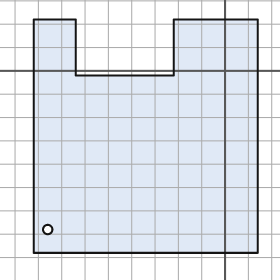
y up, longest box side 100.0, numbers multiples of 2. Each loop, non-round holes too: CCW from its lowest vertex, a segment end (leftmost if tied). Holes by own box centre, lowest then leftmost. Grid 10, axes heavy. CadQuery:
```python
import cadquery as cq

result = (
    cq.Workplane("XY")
    .moveTo(-82.0, -78.0)
    .lineTo(14.0, -78.0)
    .lineTo(14.0, 22.0)
    .lineTo(-22.0, 22.0)
    .lineTo(-22.0, -2.0)
    .lineTo(-64.0, -2.0)
    .lineTo(-64.0, 22.0)
    .lineTo(-82.0, 22.0)
    .close()
    .moveTo(-76.0, -68.0)
    .circle(2.0)
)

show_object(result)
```